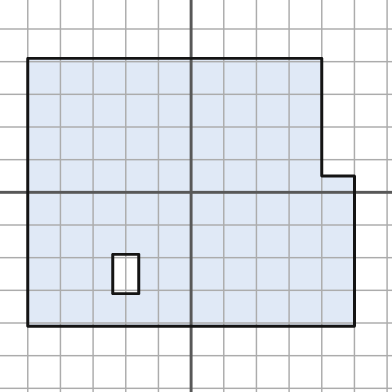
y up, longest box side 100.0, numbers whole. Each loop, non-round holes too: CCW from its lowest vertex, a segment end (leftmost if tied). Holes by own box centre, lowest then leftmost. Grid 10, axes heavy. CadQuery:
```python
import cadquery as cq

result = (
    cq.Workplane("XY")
    .moveTo(-50.0, -41.0)
    .lineTo(50.0, -41.0)
    .lineTo(50.0, 5.0)
    .lineTo(40.0, 5.0)
    .lineTo(40.0, 41.0)
    .lineTo(-50.0, 41.0)
    .close()
    .moveTo(-24.0, -31.0)
    .lineTo(-16.0, -31.0)
    .lineTo(-16.0, -19.0)
    .lineTo(-24.0, -19.0)
    .close()
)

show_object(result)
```